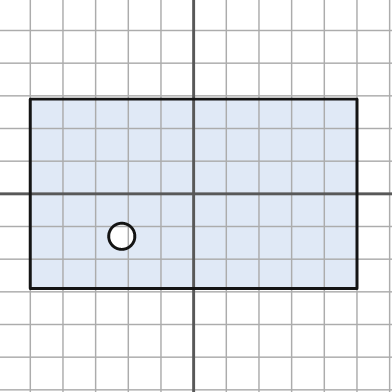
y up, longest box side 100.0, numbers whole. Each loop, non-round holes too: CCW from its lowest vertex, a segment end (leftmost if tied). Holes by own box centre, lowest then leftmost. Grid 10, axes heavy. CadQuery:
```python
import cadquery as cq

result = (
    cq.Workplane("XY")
    .moveTo(-50.0, -29.0)
    .lineTo(50.0, -29.0)
    .lineTo(50.0, 29.0)
    .lineTo(-50.0, 29.0)
    .close()
    .moveTo(-22.0, -13.0)
    .circle(4.0)
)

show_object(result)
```